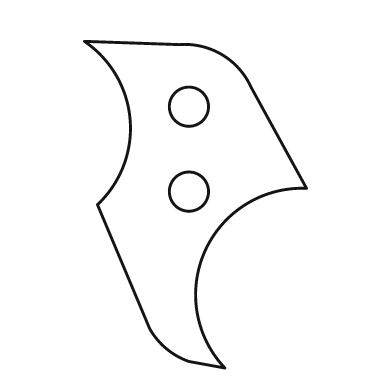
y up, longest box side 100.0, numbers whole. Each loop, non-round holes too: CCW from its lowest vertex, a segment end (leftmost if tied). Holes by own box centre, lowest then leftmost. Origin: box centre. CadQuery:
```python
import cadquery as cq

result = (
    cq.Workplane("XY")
    .moveTo(9.0, -50.0)
    .threePointArc((3.0, -14.0), (34.0, 5.0))
    .lineTo(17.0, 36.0)
    .threePointArc((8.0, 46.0), (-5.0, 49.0))
    .lineTo(-34.0, 50.0)
    .threePointArc((-20.0, 26.0), (-30.0, 0.0))
    .lineTo(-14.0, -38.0)
    .threePointArc((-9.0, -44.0), (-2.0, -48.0))
    .close()
    .moveTo(-2.0, 4.0)
    .circle(6.0)
    .moveTo(-2.0, 30.0)
    .circle(6.0)
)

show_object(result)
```